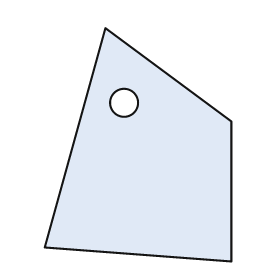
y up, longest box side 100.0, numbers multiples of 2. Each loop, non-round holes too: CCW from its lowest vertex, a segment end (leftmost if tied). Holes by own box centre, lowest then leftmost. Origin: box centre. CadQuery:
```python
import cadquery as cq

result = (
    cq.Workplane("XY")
    .moveTo(40.0, -50.0)
    .lineTo(40.0, 10.0)
    .lineTo(-14.0, 50.0)
    .lineTo(-40.0, -44.0)
    .close()
    .moveTo(-6.0, 18.0)
    .circle(6.0)
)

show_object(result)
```